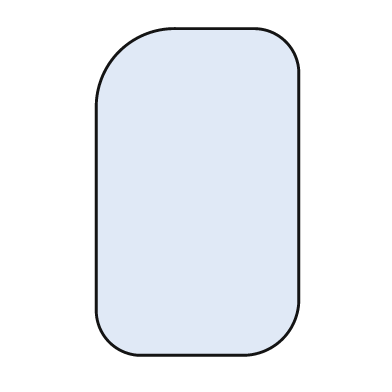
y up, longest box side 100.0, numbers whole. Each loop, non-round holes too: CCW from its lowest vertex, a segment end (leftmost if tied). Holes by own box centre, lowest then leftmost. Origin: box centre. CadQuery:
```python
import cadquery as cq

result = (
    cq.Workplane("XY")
    .moveTo(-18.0, -50.0)
    .lineTo(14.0, -50.0)
    .threePointArc((26.0, -45.0), (31.0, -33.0))
    .lineTo(31.0, 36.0)
    .threePointArc((27.0, 46.0), (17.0, 50.0))
    .lineTo(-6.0, 50.0)
    .threePointArc((-24.0, 43.0), (-31.0, 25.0))
    .lineTo(-31.0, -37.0)
    .threePointArc((-27.0, -46.0), (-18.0, -50.0))
    .close()
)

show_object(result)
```